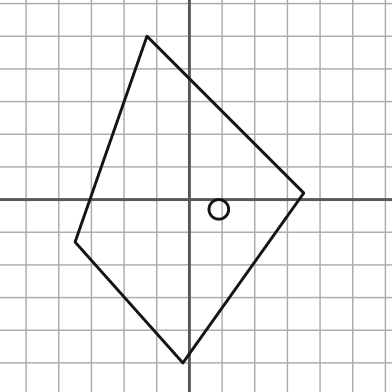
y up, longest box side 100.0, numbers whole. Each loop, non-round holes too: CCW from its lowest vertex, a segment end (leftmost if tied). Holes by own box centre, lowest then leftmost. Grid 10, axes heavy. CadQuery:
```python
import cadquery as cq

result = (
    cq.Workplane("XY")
    .moveTo(-2.0, -50.0)
    .lineTo(35.0, 2.0)
    .lineTo(-13.0, 50.0)
    .lineTo(-35.0, -13.0)
    .close()
    .moveTo(9.0, -3.0)
    .circle(3.0)
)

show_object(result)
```